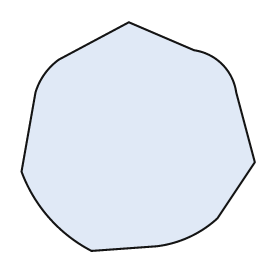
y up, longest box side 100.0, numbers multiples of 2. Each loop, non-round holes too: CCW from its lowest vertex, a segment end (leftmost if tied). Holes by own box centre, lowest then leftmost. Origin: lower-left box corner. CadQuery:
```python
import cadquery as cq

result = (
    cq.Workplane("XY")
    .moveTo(30.0, 0.0)
    .lineTo(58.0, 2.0)
    .threePointArc((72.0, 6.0), (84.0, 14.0))
    .lineTo(100.0, 38.0)
    .lineTo(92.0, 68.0)
    .threePointArc((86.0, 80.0), (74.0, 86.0))
    .lineTo(46.0, 98.0)
    .lineTo(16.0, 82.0)
    .threePointArc((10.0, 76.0), (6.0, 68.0))
    .lineTo(0.0, 34.0)
    .threePointArc((12.0, 14.0), (30.0, 0.0))
    .close()
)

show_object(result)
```